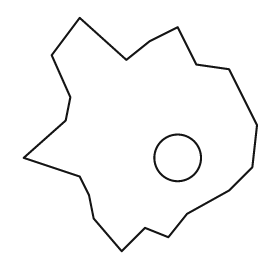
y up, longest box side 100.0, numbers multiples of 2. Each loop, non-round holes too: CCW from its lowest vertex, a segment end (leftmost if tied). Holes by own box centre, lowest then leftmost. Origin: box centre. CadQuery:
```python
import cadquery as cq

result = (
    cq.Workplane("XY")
    .moveTo(-8.0, -50.0)
    .lineTo(2.0, -40.0)
    .lineTo(12.0, -44.0)
    .lineTo(20.0, -34.0)
    .lineTo(38.0, -24.0)
    .lineTo(48.0, -14.0)
    .lineTo(50.0, 4.0)
    .lineTo(38.0, 28.0)
    .lineTo(24.0, 30.0)
    .lineTo(16.0, 46.0)
    .lineTo(4.0, 40.0)
    .lineTo(-6.0, 32.0)
    .lineTo(-26.0, 50.0)
    .lineTo(-38.0, 34.0)
    .lineTo(-30.0, 16.0)
    .lineTo(-32.0, 6.0)
    .lineTo(-50.0, -10.0)
    .lineTo(-26.0, -18.0)
    .lineTo(-22.0, -26.0)
    .lineTo(-20.0, -36.0)
    .close()
    .moveTo(16.0, -10.0)
    .circle(10.0)
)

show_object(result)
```